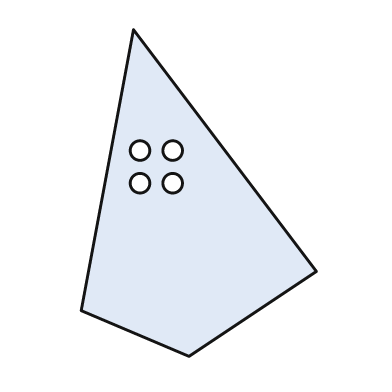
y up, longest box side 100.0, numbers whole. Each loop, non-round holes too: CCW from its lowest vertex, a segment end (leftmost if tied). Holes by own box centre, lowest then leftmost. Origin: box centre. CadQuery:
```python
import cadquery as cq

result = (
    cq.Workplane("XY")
    .moveTo(-3.0, -50.0)
    .lineTo(36.0, -24.0)
    .lineTo(-20.0, 50.0)
    .lineTo(-36.0, -36.0)
    .close()
    .moveTo(-18.0, 3.0)
    .circle(3.0)
    .moveTo(-8.0, 3.0)
    .circle(3.0)
    .moveTo(-18.0, 13.0)
    .circle(3.0)
    .moveTo(-8.0, 13.0)
    .circle(3.0)
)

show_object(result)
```